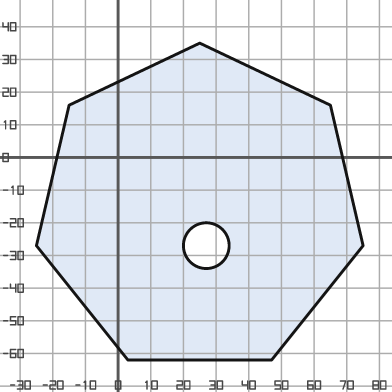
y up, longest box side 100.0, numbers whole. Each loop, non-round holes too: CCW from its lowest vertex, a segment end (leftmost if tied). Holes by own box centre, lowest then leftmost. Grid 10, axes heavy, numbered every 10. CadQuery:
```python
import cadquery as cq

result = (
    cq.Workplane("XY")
    .moveTo(3.0, -62.0)
    .lineTo(47.0, -62.0)
    .lineTo(75.0, -27.0)
    .lineTo(65.0, 16.0)
    .lineTo(25.0, 35.0)
    .lineTo(-15.0, 16.0)
    .lineTo(-25.0, -27.0)
    .close()
    .moveTo(27.0, -27.0)
    .circle(7.0)
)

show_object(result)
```